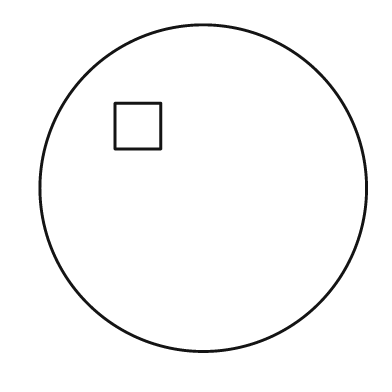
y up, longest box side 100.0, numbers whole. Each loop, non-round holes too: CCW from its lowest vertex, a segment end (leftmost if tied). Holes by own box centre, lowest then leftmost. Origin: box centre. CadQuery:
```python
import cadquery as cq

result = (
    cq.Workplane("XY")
    .moveTo(0.0, 0.0)
    .circle(50.0)
    .moveTo(-27.0, 12.0)
    .lineTo(-13.0, 12.0)
    .lineTo(-13.0, 26.0)
    .lineTo(-27.0, 26.0)
    .close()
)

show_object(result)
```